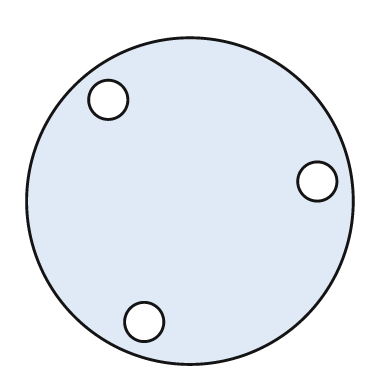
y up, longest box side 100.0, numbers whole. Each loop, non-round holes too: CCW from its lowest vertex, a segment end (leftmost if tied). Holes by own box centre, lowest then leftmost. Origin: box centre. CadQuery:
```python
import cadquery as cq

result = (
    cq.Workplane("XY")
    .moveTo(0.0, 0.0)
    .circle(50.0)
    .moveTo(-14.0, -37.0)
    .circle(6.0)
    .moveTo(39.0, 6.0)
    .circle(6.0)
    .moveTo(-25.0, 31.0)
    .circle(6.0)
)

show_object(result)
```